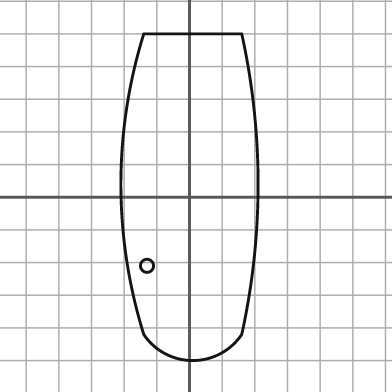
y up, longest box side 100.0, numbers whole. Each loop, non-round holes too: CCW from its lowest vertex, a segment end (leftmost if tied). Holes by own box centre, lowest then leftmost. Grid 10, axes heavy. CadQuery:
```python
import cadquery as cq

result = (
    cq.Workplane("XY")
    .moveTo(-14.0, -42.0)
    .threePointArc((1.0, -50.0), (16.0, -42.0))
    .threePointArc((21.0, 4.0), (16.0, 50.0))
    .lineTo(-14.0, 50.0)
    .threePointArc((-21.0, 4.0), (-14.0, -42.0))
    .close()
    .moveTo(-13.0, -21.0)
    .circle(2.0)
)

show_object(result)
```